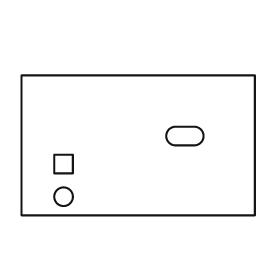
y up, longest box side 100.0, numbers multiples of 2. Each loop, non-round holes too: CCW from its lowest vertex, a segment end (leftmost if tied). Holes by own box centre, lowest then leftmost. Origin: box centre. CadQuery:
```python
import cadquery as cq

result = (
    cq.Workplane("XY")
    .moveTo(-50.0, -30.0)
    .lineTo(50.0, -30.0)
    .lineTo(50.0, 30.0)
    .lineTo(-50.0, 30.0)
    .close()
    .moveTo(-32.0, -22.0)
    .circle(4.0)
    .moveTo(-36.0, -12.0)
    .lineTo(-28.0, -12.0)
    .lineTo(-28.0, -4.0)
    .lineTo(-36.0, -4.0)
    .close()
    .moveTo(16.0, 0.0)
    .lineTo(24.0, 0.0)
    .threePointArc((28.0, 4.0), (24.0, 8.0))
    .lineTo(16.0, 8.0)
    .threePointArc((12.0, 4.0), (16.0, 0.0))
    .close()
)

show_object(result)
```